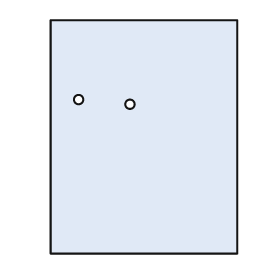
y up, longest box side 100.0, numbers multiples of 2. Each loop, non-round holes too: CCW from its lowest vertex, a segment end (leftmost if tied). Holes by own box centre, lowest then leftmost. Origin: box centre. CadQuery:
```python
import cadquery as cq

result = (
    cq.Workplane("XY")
    .moveTo(-40.0, -50.0)
    .lineTo(40.0, -50.0)
    .lineTo(40.0, 50.0)
    .lineTo(-40.0, 50.0)
    .close()
    .moveTo(-6.0, 14.0)
    .circle(2.0)
    .moveTo(-28.0, 16.0)
    .circle(2.0)
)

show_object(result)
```